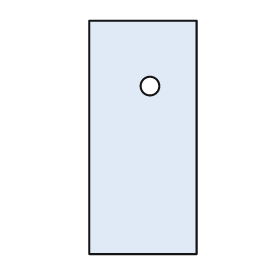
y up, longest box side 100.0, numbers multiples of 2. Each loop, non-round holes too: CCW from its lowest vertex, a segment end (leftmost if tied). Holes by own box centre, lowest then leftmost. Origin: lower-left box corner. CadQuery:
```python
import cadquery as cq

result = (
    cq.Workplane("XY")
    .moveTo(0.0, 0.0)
    .lineTo(46.0, 0.0)
    .lineTo(46.0, 100.0)
    .lineTo(0.0, 100.0)
    .close()
    .moveTo(26.0, 72.0)
    .circle(4.0)
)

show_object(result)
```